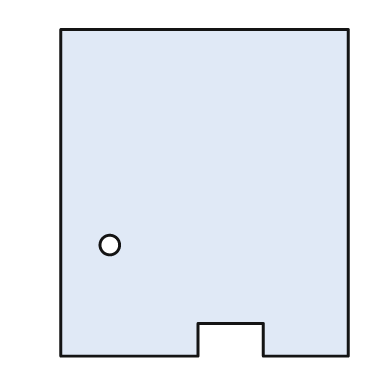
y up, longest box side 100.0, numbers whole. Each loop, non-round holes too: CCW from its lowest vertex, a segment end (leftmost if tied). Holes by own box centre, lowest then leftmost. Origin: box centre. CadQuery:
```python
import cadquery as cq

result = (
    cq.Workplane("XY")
    .moveTo(-44.0, -50.0)
    .lineTo(-2.0, -50.0)
    .lineTo(-2.0, -40.0)
    .lineTo(18.0, -40.0)
    .lineTo(18.0, -50.0)
    .lineTo(44.0, -50.0)
    .lineTo(44.0, 50.0)
    .lineTo(-44.0, 50.0)
    .close()
    .moveTo(-29.0, -16.0)
    .circle(3.0)
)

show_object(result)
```